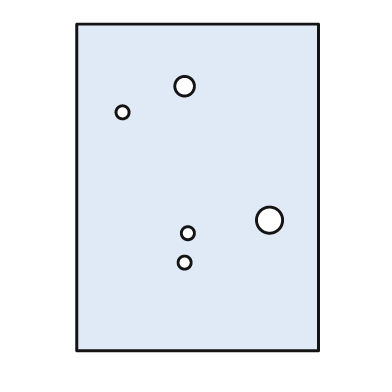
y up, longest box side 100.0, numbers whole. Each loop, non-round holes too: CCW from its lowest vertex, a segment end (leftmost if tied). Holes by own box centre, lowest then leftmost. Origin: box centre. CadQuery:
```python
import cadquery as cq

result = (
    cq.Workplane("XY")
    .moveTo(-37.0, -50.0)
    .lineTo(37.0, -50.0)
    .lineTo(37.0, 50.0)
    .lineTo(-37.0, 50.0)
    .close()
    .moveTo(-4.0, -23.0)
    .circle(2.0)
    .moveTo(-3.0, -14.0)
    .circle(2.0)
    .moveTo(22.0, -10.0)
    .circle(4.0)
    .moveTo(-23.0, 23.0)
    .circle(2.0)
    .moveTo(-4.0, 31.0)
    .circle(3.0)
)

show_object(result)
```